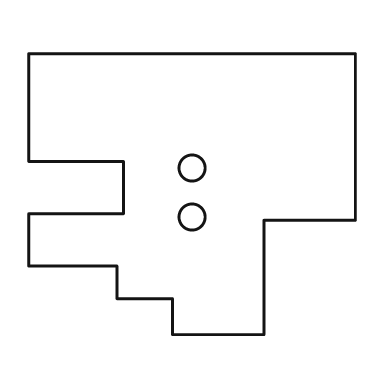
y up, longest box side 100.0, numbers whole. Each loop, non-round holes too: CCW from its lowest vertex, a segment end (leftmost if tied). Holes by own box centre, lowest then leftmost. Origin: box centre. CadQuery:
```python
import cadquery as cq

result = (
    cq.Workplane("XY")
    .moveTo(-6.0, -43.0)
    .lineTo(22.0, -43.0)
    .lineTo(22.0, -8.0)
    .lineTo(50.0, -8.0)
    .lineTo(50.0, 43.0)
    .lineTo(-50.0, 43.0)
    .lineTo(-50.0, 10.0)
    .lineTo(-21.0, 10.0)
    .lineTo(-21.0, -6.0)
    .lineTo(-50.0, -6.0)
    .lineTo(-50.0, -22.0)
    .lineTo(-23.0, -22.0)
    .lineTo(-23.0, -32.0)
    .lineTo(-6.0, -32.0)
    .close()
    .moveTo(0.0, -7.0)
    .circle(4.0)
    .moveTo(0.0, 8.0)
    .circle(4.0)
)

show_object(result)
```